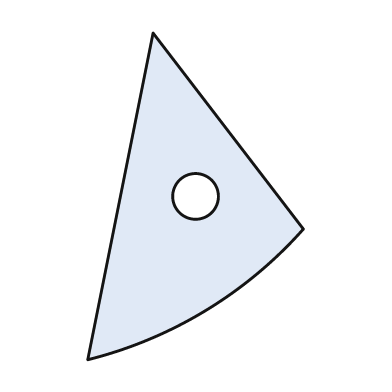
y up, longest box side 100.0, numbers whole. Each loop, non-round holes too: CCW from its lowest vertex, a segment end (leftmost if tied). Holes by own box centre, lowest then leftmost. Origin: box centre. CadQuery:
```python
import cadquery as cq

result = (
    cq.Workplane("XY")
    .moveTo(-33.0, -50.0)
    .threePointArc((3.0, -35.0), (33.0, -10.0))
    .lineTo(-13.0, 50.0)
    .close()
    .moveTo(0.0, 0.0)
    .circle(7.0)
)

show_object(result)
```